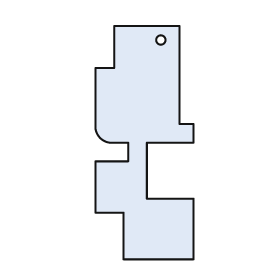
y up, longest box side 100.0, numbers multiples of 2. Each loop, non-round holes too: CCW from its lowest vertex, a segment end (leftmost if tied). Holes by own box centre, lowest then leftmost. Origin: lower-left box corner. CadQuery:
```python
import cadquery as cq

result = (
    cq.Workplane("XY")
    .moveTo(12.0, 0.0)
    .lineTo(42.0, 0.0)
    .lineTo(42.0, 26.0)
    .lineTo(22.0, 26.0)
    .lineTo(22.0, 50.0)
    .lineTo(42.0, 50.0)
    .lineTo(42.0, 58.0)
    .lineTo(36.0, 58.0)
    .lineTo(36.0, 100.0)
    .lineTo(8.0, 100.0)
    .lineTo(8.0, 82.0)
    .lineTo(0.0, 82.0)
    .lineTo(0.0, 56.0)
    .threePointArc((2.0, 52.0), (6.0, 50.0))
    .lineTo(14.0, 50.0)
    .lineTo(14.0, 42.0)
    .lineTo(0.0, 42.0)
    .lineTo(0.0, 20.0)
    .lineTo(12.0, 20.0)
    .close()
    .moveTo(28.0, 94.0)
    .circle(2.0)
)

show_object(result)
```